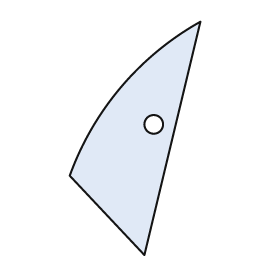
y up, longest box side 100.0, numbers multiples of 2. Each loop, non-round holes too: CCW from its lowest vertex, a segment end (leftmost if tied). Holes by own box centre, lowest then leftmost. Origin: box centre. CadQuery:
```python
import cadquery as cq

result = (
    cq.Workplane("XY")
    .moveTo(4.0, -50.0)
    .lineTo(28.0, 50.0)
    .threePointArc((-6.0, 22.0), (-28.0, -16.0))
    .close()
    .moveTo(8.0, 6.0)
    .circle(4.0)
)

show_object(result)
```